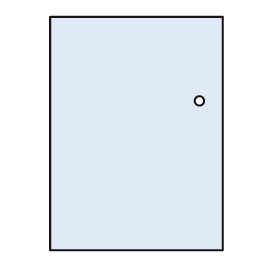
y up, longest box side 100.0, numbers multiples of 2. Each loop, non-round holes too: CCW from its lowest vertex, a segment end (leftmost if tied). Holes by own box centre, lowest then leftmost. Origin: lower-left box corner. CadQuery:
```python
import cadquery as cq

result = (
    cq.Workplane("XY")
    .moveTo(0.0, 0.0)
    .lineTo(74.0, 0.0)
    .lineTo(74.0, 100.0)
    .lineTo(0.0, 100.0)
    .close()
    .moveTo(64.0, 64.0)
    .circle(2.0)
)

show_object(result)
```